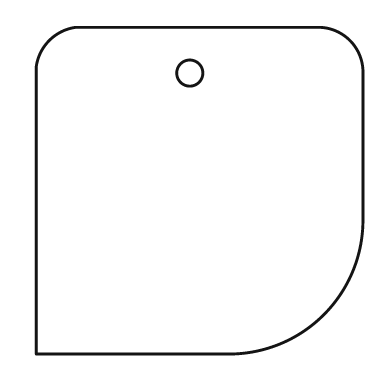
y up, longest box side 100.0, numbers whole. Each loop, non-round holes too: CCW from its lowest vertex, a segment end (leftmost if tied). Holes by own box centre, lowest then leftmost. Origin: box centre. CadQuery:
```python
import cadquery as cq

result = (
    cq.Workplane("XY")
    .moveTo(-50.0, -50.0)
    .lineTo(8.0, -50.0)
    .threePointArc((38.0, -38.0), (50.0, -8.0))
    .lineTo(50.0, 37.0)
    .threePointArc((46.0, 46.0), (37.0, 50.0))
    .lineTo(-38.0, 50.0)
    .threePointArc((-46.0, 46.0), (-50.0, 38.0))
    .close()
    .moveTo(-3.0, 36.0)
    .circle(4.0)
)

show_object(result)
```